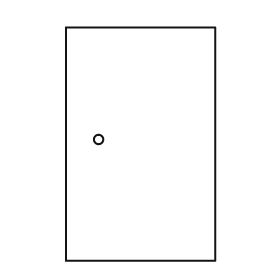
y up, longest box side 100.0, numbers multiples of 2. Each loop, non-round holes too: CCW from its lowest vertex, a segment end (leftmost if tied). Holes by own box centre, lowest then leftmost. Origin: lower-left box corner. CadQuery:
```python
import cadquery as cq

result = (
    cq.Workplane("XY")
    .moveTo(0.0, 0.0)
    .lineTo(64.0, 0.0)
    .lineTo(64.0, 100.0)
    .lineTo(0.0, 100.0)
    .close()
    .moveTo(14.0, 52.0)
    .circle(2.0)
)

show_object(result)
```